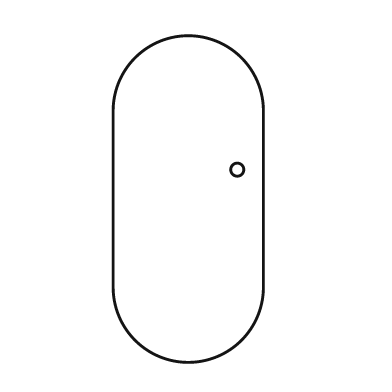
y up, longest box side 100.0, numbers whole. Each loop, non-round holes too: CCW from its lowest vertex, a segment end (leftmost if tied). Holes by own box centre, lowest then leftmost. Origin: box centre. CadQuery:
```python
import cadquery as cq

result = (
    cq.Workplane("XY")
    .moveTo(-23.0, -27.0)
    .threePointArc((0.0, -50.0), (23.0, -27.0))
    .lineTo(23.0, 27.0)
    .threePointArc((0.0, 50.0), (-23.0, 27.0))
    .close()
    .moveTo(15.0, 9.0)
    .circle(2.0)
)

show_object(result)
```